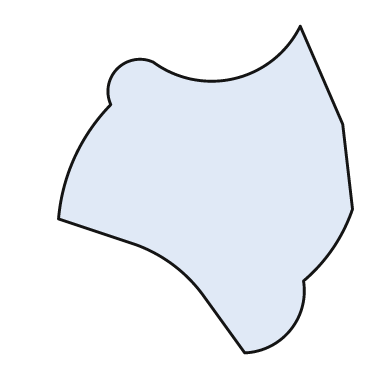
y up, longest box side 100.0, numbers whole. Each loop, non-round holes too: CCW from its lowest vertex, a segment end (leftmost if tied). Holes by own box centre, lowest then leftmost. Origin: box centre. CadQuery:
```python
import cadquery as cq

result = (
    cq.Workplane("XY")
    .moveTo(12.0, -50.0)
    .threePointArc((26.0, -43.0), (30.0, -28.0))
    .threePointArc((39.0, -18.0), (45.0, -6.0))
    .lineTo(42.0, 20.0)
    .lineTo(29.0, 50.0)
    .threePointArc((9.0, 34.0), (-16.0, 39.0))
    .threePointArc((-27.0, 37.0), (-29.0, 26.0))
    .threePointArc((-40.0, 10.0), (-45.0, -9.0))
    .lineTo(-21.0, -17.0)
    .threePointArc((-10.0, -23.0), (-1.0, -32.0))
    .close()
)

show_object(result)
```